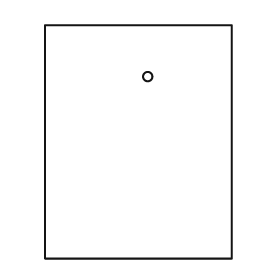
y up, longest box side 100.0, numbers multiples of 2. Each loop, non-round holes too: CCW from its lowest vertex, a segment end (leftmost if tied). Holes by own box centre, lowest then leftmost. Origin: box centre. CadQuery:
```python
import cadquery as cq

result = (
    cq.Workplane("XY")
    .moveTo(-40.0, -50.0)
    .lineTo(40.0, -50.0)
    .lineTo(40.0, 50.0)
    .lineTo(-40.0, 50.0)
    .close()
    .moveTo(4.0, 28.0)
    .circle(2.0)
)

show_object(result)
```